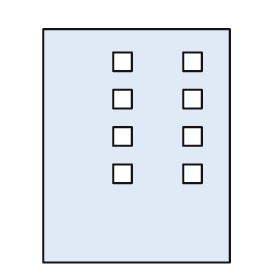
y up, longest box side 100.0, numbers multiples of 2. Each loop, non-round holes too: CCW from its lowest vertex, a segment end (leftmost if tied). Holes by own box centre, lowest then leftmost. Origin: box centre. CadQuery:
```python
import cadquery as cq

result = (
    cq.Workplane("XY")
    .moveTo(-40.0, -50.0)
    .lineTo(40.0, -50.0)
    .lineTo(40.0, 50.0)
    .lineTo(-40.0, 50.0)
    .close()
    .moveTo(-10.0, -16.0)
    .lineTo(-2.0, -16.0)
    .lineTo(-2.0, -8.0)
    .lineTo(-10.0, -8.0)
    .close()
    .moveTo(20.0, -16.0)
    .lineTo(28.0, -16.0)
    .lineTo(28.0, -8.0)
    .lineTo(20.0, -8.0)
    .close()
    .moveTo(-10.0, 0.0)
    .lineTo(-2.0, 0.0)
    .lineTo(-2.0, 8.0)
    .lineTo(-10.0, 8.0)
    .close()
    .moveTo(20.0, 0.0)
    .lineTo(28.0, 0.0)
    .lineTo(28.0, 8.0)
    .lineTo(20.0, 8.0)
    .close()
    .moveTo(-10.0, 16.0)
    .lineTo(-2.0, 16.0)
    .lineTo(-2.0, 24.0)
    .lineTo(-10.0, 24.0)
    .close()
    .moveTo(20.0, 16.0)
    .lineTo(28.0, 16.0)
    .lineTo(28.0, 24.0)
    .lineTo(20.0, 24.0)
    .close()
    .moveTo(-10.0, 32.0)
    .lineTo(-2.0, 32.0)
    .lineTo(-2.0, 40.0)
    .lineTo(-10.0, 40.0)
    .close()
    .moveTo(20.0, 32.0)
    .lineTo(28.0, 32.0)
    .lineTo(28.0, 40.0)
    .lineTo(20.0, 40.0)
    .close()
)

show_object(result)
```